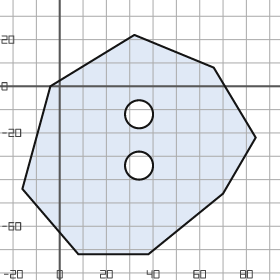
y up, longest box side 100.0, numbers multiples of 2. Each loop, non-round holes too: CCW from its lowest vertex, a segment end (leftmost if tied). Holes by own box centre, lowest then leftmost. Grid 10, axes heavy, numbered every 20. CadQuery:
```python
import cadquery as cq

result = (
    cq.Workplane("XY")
    .moveTo(8.0, -72.0)
    .lineTo(38.0, -72.0)
    .lineTo(70.0, -46.0)
    .lineTo(84.0, -22.0)
    .lineTo(66.0, 8.0)
    .lineTo(32.0, 22.0)
    .lineTo(-4.0, 0.0)
    .lineTo(-16.0, -44.0)
    .close()
    .moveTo(34.0, -34.0)
    .circle(6.0)
    .moveTo(34.0, -12.0)
    .circle(6.0)
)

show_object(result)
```